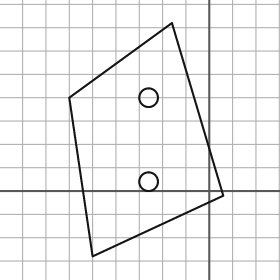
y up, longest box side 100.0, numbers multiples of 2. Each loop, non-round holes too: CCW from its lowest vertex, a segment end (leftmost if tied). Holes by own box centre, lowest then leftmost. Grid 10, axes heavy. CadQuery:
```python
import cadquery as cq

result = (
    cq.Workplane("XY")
    .moveTo(-50.0, -28.0)
    .lineTo(6.0, -2.0)
    .lineTo(-16.0, 72.0)
    .lineTo(-60.0, 40.0)
    .close()
    .moveTo(-26.0, 4.0)
    .circle(4.0)
    .moveTo(-26.0, 40.0)
    .circle(4.0)
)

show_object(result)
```